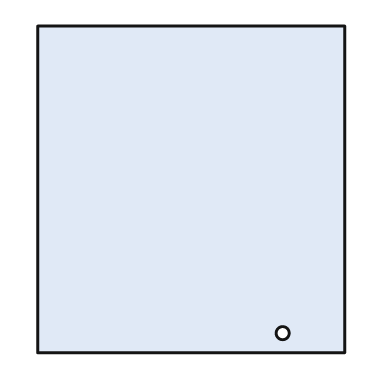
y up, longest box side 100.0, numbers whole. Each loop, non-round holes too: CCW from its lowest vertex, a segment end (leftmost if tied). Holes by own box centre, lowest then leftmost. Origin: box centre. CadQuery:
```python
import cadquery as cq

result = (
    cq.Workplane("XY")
    .moveTo(-47.0, -50.0)
    .lineTo(47.0, -50.0)
    .lineTo(47.0, 50.0)
    .lineTo(-47.0, 50.0)
    .close()
    .moveTo(28.0, -44.0)
    .circle(2.0)
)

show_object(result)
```